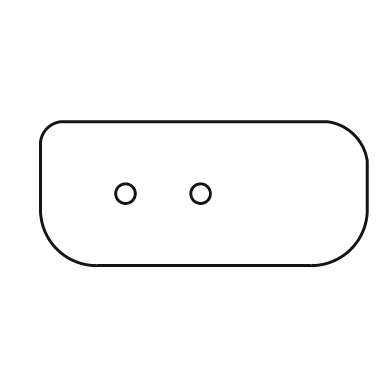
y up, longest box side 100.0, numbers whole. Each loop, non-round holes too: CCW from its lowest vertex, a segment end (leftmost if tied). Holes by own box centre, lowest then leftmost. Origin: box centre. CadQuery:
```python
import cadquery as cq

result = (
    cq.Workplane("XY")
    .moveTo(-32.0, -22.0)
    .lineTo(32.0, -22.0)
    .threePointArc((45.0, -17.0), (50.0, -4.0))
    .lineTo(50.0, 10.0)
    .threePointArc((46.0, 18.0), (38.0, 22.0))
    .lineTo(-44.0, 22.0)
    .threePointArc((-48.0, 20.0), (-50.0, 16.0))
    .lineTo(-50.0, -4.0)
    .threePointArc((-45.0, -17.0), (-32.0, -22.0))
    .close()
    .moveTo(-24.0, 0.0)
    .circle(3.0)
    .moveTo(-1.0, 0.0)
    .circle(3.0)
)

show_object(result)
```